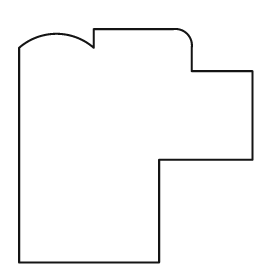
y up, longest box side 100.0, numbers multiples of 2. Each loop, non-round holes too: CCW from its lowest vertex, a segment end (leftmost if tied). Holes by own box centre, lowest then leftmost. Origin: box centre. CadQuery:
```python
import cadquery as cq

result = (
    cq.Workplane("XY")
    .moveTo(-50.0, -50.0)
    .lineTo(10.0, -50.0)
    .lineTo(10.0, -6.0)
    .lineTo(50.0, -6.0)
    .lineTo(50.0, 32.0)
    .lineTo(24.0, 32.0)
    .lineTo(24.0, 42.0)
    .threePointArc((22.0, 48.0), (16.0, 50.0))
    .lineTo(-18.0, 50.0)
    .lineTo(-18.0, 42.0)
    .threePointArc((-34.0, 48.0), (-50.0, 42.0))
    .close()
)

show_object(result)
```